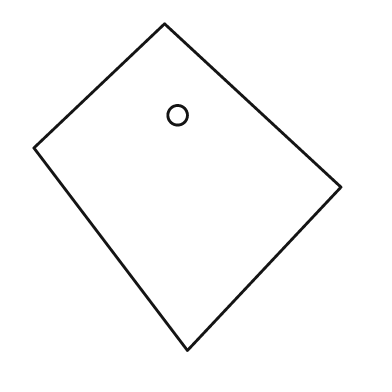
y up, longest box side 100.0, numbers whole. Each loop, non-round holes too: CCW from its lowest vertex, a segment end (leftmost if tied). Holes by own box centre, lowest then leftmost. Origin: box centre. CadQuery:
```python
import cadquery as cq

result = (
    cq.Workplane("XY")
    .moveTo(0.0, -50.0)
    .lineTo(47.0, 0.0)
    .lineTo(-7.0, 50.0)
    .lineTo(-47.0, 12.0)
    .close()
    .moveTo(-3.0, 22.0)
    .circle(3.0)
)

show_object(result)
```